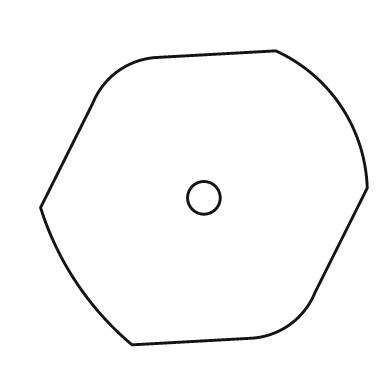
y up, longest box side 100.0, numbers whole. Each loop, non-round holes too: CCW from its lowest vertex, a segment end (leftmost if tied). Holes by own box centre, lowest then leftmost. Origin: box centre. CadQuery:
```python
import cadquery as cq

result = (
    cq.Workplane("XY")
    .moveTo(-22.0, -45.0)
    .lineTo(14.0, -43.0)
    .threePointArc((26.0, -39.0), (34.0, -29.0))
    .lineTo(50.0, 3.0)
    .threePointArc((42.0, 28.0), (22.0, 45.0))
    .lineTo(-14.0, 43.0)
    .threePointArc((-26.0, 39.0), (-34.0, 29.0))
    .lineTo(-50.0, -3.0)
    .threePointArc((-39.0, -26.0), (-22.0, -45.0))
    .close()
    .moveTo(0.0, 0.0)
    .circle(5.0)
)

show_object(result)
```